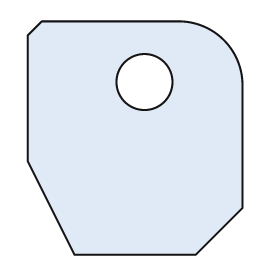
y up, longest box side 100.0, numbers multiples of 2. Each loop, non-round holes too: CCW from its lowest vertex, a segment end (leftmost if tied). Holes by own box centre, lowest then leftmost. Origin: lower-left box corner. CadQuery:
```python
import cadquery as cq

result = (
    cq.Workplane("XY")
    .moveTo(20.0, 0.0)
    .lineTo(72.0, 0.0)
    .lineTo(92.0, 20.0)
    .lineTo(92.0, 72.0)
    .threePointArc((84.0, 92.0), (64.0, 100.0))
    .lineTo(6.0, 100.0)
    .lineTo(0.0, 94.0)
    .lineTo(0.0, 40.0)
    .close()
    .moveTo(50.0, 74.0)
    .circle(12.0)
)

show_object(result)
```